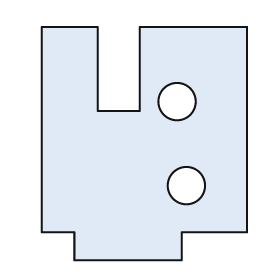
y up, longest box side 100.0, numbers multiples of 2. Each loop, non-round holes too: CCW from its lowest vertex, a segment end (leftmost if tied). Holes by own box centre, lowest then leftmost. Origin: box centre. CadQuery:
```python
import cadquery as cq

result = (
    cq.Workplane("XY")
    .moveTo(-30.0, -50.0)
    .lineTo(16.0, -50.0)
    .lineTo(16.0, -38.0)
    .lineTo(44.0, -38.0)
    .lineTo(44.0, 50.0)
    .lineTo(-2.0, 50.0)
    .lineTo(-2.0, 14.0)
    .lineTo(-20.0, 14.0)
    .lineTo(-20.0, 50.0)
    .lineTo(-44.0, 50.0)
    .lineTo(-44.0, -38.0)
    .lineTo(-30.0, -38.0)
    .close()
    .moveTo(18.0, -18.0)
    .circle(8.0)
    .moveTo(14.0, 18.0)
    .circle(8.0)
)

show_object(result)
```